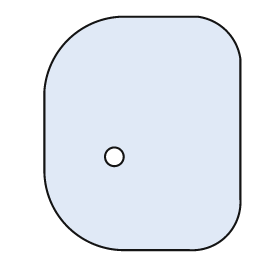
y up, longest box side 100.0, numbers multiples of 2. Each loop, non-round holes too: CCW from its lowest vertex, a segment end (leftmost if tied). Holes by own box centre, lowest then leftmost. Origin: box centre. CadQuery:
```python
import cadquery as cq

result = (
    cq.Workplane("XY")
    .moveTo(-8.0, -50.0)
    .lineTo(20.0, -50.0)
    .threePointArc((36.0, -44.0), (42.0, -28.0))
    .lineTo(42.0, 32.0)
    .threePointArc((36.0, 44.0), (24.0, 50.0))
    .lineTo(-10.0, 50.0)
    .threePointArc((-32.0, 40.0), (-42.0, 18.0))
    .lineTo(-42.0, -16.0)
    .threePointArc((-32.0, -40.0), (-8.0, -50.0))
    .close()
    .moveTo(-12.0, -10.0)
    .circle(4.0)
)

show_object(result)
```